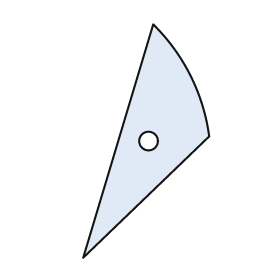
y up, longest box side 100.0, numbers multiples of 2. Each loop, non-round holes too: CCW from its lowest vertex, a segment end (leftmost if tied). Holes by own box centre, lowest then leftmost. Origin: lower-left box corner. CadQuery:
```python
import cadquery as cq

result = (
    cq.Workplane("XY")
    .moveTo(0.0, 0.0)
    .lineTo(54.0, 52.0)
    .threePointArc((46.0, 78.0), (30.0, 100.0))
    .close()
    .moveTo(28.0, 50.0)
    .circle(4.0)
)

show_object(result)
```